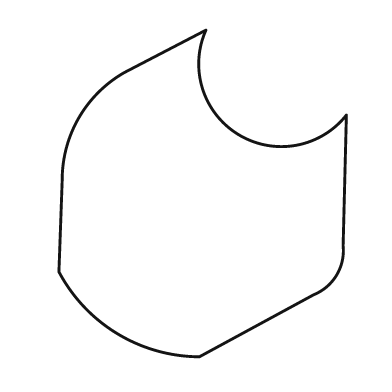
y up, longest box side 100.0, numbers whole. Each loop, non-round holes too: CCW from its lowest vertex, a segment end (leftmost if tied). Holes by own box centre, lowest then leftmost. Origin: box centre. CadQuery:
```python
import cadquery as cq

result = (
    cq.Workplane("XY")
    .moveTo(-1.0, -50.0)
    .lineTo(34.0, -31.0)
    .threePointArc((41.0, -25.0), (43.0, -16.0))
    .lineTo(44.0, 24.0)
    .threePointArc((11.0, 18.0), (1.0, 50.0))
    .lineTo(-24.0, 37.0)
    .threePointArc((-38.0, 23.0), (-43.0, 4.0))
    .lineTo(-44.0, -24.0)
    .threePointArc((-26.0, -43.0), (-1.0, -50.0))
    .close()
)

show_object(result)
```